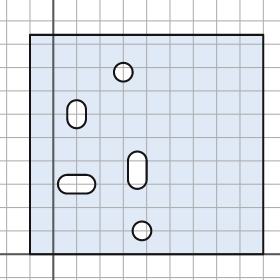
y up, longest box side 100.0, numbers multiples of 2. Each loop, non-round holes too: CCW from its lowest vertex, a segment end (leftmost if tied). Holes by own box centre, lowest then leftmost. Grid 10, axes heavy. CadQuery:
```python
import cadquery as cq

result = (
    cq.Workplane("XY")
    .moveTo(-10.0, 0.0)
    .lineTo(90.0, 0.0)
    .lineTo(90.0, 94.0)
    .lineTo(-10.0, 94.0)
    .close()
    .moveTo(38.0, 10.0)
    .circle(4.0)
    .moveTo(6.0, 26.0)
    .lineTo(14.0, 26.0)
    .threePointArc((18.0, 30.0), (14.0, 34.0))
    .lineTo(6.0, 34.0)
    .threePointArc((2.0, 30.0), (6.0, 26.0))
    .close()
    .moveTo(32.0, 32.0)
    .threePointArc((36.0, 28.0), (40.0, 32.0))
    .lineTo(40.0, 40.0)
    .threePointArc((36.0, 44.0), (32.0, 40.0))
    .close()
    .moveTo(6.0, 58.0)
    .threePointArc((10.0, 54.0), (14.0, 58.0))
    .lineTo(14.0, 62.0)
    .threePointArc((10.0, 66.0), (6.0, 62.0))
    .close()
    .moveTo(30.0, 78.0)
    .circle(4.0)
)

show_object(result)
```